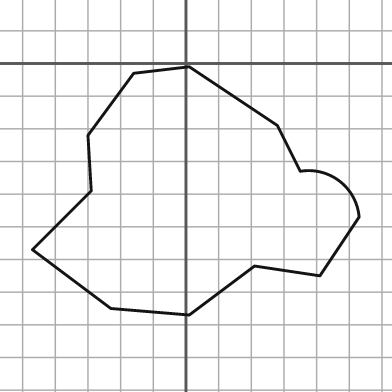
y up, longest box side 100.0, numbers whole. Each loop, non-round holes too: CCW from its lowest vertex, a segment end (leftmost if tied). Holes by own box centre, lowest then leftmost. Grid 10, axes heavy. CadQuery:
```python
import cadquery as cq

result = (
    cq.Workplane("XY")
    .moveTo(1.0, -77.0)
    .lineTo(21.0, -62.0)
    .lineTo(41.0, -65.0)
    .lineTo(53.0, -47.0)
    .threePointArc((47.0, -36.0), (35.0, -33.0))
    .lineTo(28.0, -19.0)
    .lineTo(1.0, -1.0)
    .lineTo(-16.0, -3.0)
    .lineTo(-30.0, -22.0)
    .lineTo(-29.0, -39.0)
    .lineTo(-47.0, -57.0)
    .lineTo(-23.0, -75.0)
    .close()
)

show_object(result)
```